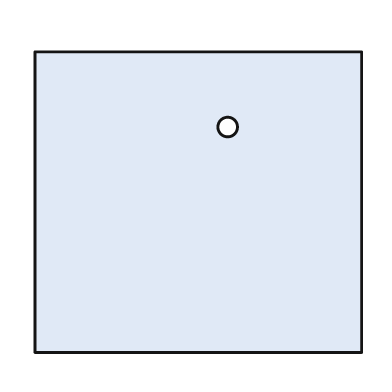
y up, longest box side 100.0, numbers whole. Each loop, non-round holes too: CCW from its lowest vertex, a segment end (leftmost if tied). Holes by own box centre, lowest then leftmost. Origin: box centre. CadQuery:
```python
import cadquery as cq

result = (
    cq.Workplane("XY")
    .moveTo(-50.0, -46.0)
    .lineTo(50.0, -46.0)
    .lineTo(50.0, 46.0)
    .lineTo(-50.0, 46.0)
    .close()
    .moveTo(9.0, 23.0)
    .circle(3.0)
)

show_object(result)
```